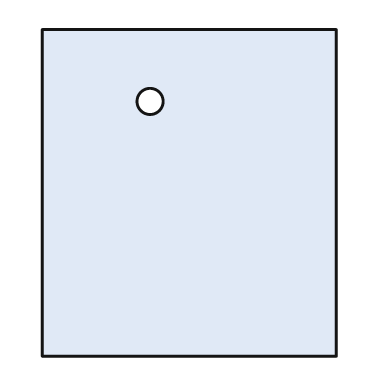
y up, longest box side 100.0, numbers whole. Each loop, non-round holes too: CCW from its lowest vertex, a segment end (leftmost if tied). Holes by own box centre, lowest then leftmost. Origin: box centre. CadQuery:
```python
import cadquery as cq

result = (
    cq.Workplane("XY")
    .moveTo(-45.0, -50.0)
    .lineTo(45.0, -50.0)
    .lineTo(45.0, 50.0)
    .lineTo(-45.0, 50.0)
    .close()
    .moveTo(-12.0, 28.0)
    .circle(4.0)
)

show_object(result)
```